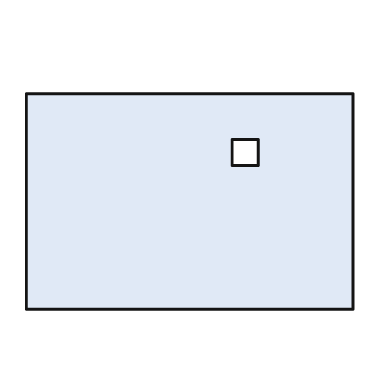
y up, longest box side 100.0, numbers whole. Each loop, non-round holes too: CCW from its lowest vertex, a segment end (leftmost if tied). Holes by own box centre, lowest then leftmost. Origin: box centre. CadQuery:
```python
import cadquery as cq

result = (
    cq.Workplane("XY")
    .moveTo(-50.0, -33.0)
    .lineTo(50.0, -33.0)
    .lineTo(50.0, 33.0)
    .lineTo(-50.0, 33.0)
    .close()
    .moveTo(13.0, 11.0)
    .lineTo(21.0, 11.0)
    .lineTo(21.0, 19.0)
    .lineTo(13.0, 19.0)
    .close()
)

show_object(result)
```